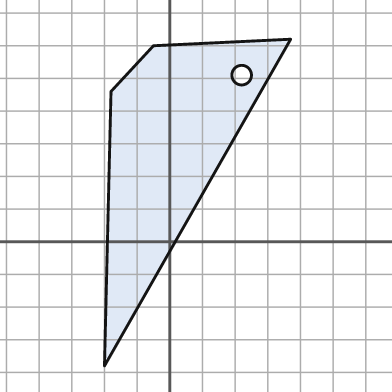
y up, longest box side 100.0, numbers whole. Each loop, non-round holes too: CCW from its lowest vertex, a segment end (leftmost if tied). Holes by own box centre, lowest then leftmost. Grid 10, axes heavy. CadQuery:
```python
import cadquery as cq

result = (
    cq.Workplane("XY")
    .moveTo(-20.0, -38.0)
    .lineTo(37.0, 62.0)
    .lineTo(-5.0, 60.0)
    .lineTo(-18.0, 46.0)
    .close()
    .moveTo(22.0, 51.0)
    .circle(3.0)
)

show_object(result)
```